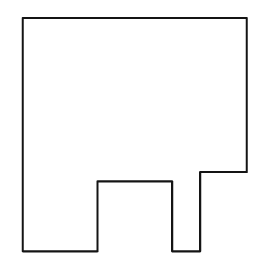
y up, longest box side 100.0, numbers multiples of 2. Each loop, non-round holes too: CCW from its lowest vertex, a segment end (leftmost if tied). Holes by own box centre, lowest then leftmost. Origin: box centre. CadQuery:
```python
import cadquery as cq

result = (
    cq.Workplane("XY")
    .moveTo(-48.0, -50.0)
    .lineTo(-16.0, -50.0)
    .lineTo(-16.0, -20.0)
    .lineTo(16.0, -20.0)
    .lineTo(16.0, -50.0)
    .lineTo(28.0, -50.0)
    .lineTo(28.0, -16.0)
    .lineTo(48.0, -16.0)
    .lineTo(48.0, 50.0)
    .lineTo(-48.0, 50.0)
    .close()
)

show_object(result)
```